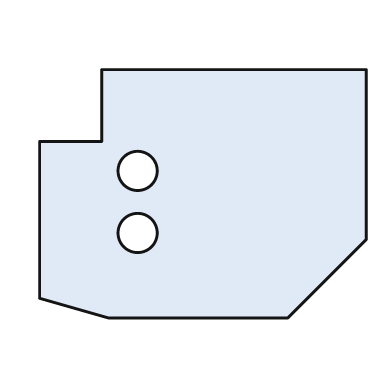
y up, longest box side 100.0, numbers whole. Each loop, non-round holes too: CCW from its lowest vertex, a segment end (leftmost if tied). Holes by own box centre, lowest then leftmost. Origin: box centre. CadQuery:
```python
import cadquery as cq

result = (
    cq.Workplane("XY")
    .moveTo(-29.0, -38.0)
    .lineTo(26.0, -38.0)
    .lineTo(50.0, -14.0)
    .lineTo(50.0, 38.0)
    .lineTo(-31.0, 38.0)
    .lineTo(-31.0, 16.0)
    .lineTo(-50.0, 16.0)
    .lineTo(-50.0, -32.0)
    .close()
    .moveTo(-20.0, -12.0)
    .circle(6.0)
    .moveTo(-20.0, 7.0)
    .circle(6.0)
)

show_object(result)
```